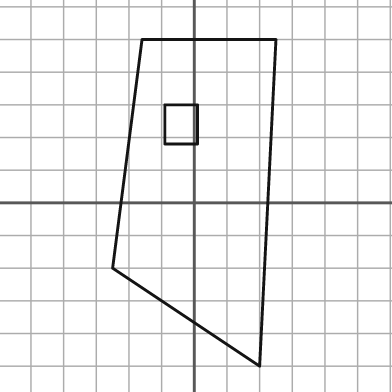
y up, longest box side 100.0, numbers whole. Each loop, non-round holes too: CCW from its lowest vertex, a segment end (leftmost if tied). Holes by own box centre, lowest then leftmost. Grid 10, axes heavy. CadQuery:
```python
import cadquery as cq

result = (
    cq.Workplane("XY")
    .moveTo(20.0, -50.0)
    .lineTo(25.0, 50.0)
    .lineTo(-16.0, 50.0)
    .lineTo(-25.0, -20.0)
    .close()
    .moveTo(-9.0, 18.0)
    .lineTo(1.0, 18.0)
    .lineTo(1.0, 30.0)
    .lineTo(-9.0, 30.0)
    .close()
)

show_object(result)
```